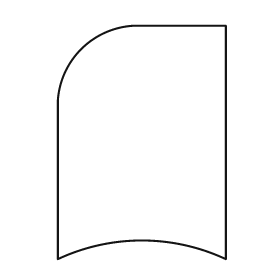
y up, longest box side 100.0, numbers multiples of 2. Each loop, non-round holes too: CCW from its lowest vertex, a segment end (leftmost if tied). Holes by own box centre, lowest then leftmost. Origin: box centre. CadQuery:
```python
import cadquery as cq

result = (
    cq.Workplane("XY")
    .moveTo(-36.0, -50.0)
    .threePointArc((0.0, -42.0), (36.0, -50.0))
    .lineTo(36.0, 50.0)
    .lineTo(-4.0, 50.0)
    .threePointArc((-26.0, 40.0), (-36.0, 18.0))
    .close()
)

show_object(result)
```